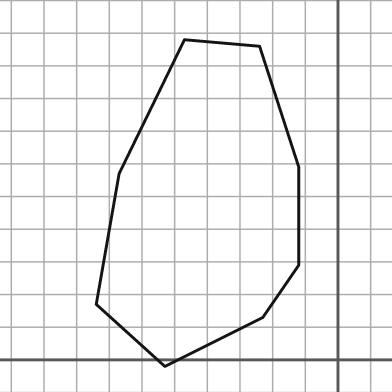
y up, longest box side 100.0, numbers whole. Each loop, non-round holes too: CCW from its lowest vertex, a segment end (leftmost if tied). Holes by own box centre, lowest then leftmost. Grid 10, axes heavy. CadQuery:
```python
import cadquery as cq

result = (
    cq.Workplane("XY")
    .moveTo(-53.0, -2.0)
    .lineTo(-23.0, 13.0)
    .lineTo(-12.0, 29.0)
    .lineTo(-12.0, 59.0)
    .lineTo(-24.0, 96.0)
    .lineTo(-47.0, 98.0)
    .lineTo(-67.0, 57.0)
    .lineTo(-74.0, 17.0)
    .close()
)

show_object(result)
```